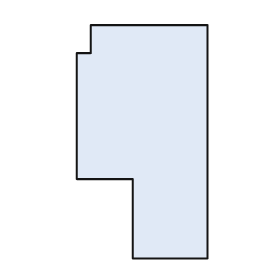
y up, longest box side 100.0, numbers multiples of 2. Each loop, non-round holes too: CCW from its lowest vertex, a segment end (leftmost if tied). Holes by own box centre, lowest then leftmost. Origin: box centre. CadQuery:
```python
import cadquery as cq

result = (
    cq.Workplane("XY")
    .moveTo(-4.0, -50.0)
    .lineTo(28.0, -50.0)
    .lineTo(28.0, 50.0)
    .lineTo(-22.0, 50.0)
    .lineTo(-22.0, 38.0)
    .lineTo(-28.0, 38.0)
    .lineTo(-28.0, -16.0)
    .lineTo(-4.0, -16.0)
    .close()
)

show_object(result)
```